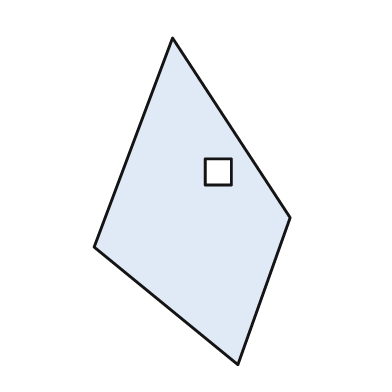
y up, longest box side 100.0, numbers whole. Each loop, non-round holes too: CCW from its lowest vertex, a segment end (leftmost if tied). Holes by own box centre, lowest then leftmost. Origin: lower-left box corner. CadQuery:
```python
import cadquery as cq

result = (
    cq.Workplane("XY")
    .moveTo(44.0, 0.0)
    .lineTo(60.0, 45.0)
    .lineTo(24.0, 100.0)
    .lineTo(0.0, 36.0)
    .close()
    .moveTo(34.0, 55.0)
    .lineTo(42.0, 55.0)
    .lineTo(42.0, 63.0)
    .lineTo(34.0, 63.0)
    .close()
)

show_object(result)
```